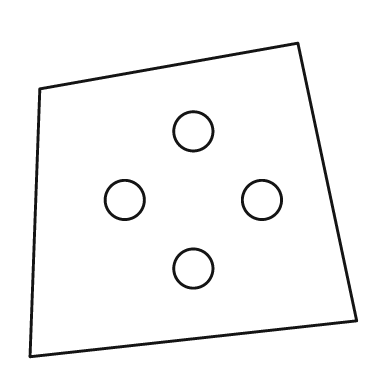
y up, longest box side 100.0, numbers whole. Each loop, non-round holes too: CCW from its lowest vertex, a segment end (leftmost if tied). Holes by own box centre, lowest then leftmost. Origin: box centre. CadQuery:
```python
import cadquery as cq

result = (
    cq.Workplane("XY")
    .moveTo(-50.0, -48.0)
    .lineTo(50.0, -37.0)
    .lineTo(32.0, 48.0)
    .lineTo(-47.0, 34.0)
    .close()
    .moveTo(0.0, -21.0)
    .circle(6.0)
    .moveTo(-21.0, 0.0)
    .circle(6.0)
    .moveTo(21.0, 0.0)
    .circle(6.0)
    .moveTo(0.0, 21.0)
    .circle(6.0)
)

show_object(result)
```